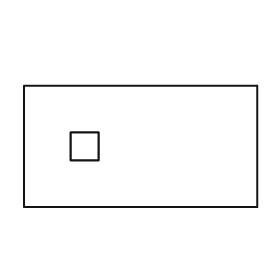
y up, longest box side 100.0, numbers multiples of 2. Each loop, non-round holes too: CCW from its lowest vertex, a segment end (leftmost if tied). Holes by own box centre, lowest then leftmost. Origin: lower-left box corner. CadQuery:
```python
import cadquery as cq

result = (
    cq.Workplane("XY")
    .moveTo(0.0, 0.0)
    .lineTo(100.0, 0.0)
    .lineTo(100.0, 52.0)
    .lineTo(0.0, 52.0)
    .close()
    .moveTo(20.0, 20.0)
    .lineTo(32.0, 20.0)
    .lineTo(32.0, 32.0)
    .lineTo(20.0, 32.0)
    .close()
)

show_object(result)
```